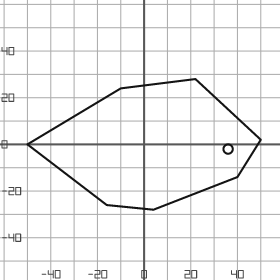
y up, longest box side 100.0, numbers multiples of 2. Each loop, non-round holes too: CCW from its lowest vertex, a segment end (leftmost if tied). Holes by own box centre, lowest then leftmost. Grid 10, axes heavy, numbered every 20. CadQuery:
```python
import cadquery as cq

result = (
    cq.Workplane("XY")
    .moveTo(4.0, -28.0)
    .lineTo(40.0, -14.0)
    .lineTo(50.0, 2.0)
    .lineTo(22.0, 28.0)
    .lineTo(-10.0, 24.0)
    .lineTo(-50.0, 0.0)
    .lineTo(-16.0, -26.0)
    .close()
    .moveTo(36.0, -2.0)
    .circle(2.0)
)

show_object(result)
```